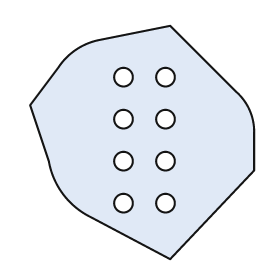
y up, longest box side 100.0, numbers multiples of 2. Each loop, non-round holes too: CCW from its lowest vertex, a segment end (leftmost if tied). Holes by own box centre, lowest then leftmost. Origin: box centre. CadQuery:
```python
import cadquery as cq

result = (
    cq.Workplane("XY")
    .moveTo(12.0, -50.0)
    .lineTo(48.0, -12.0)
    .lineTo(48.0, 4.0)
    .threePointArc((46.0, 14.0), (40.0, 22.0))
    .lineTo(12.0, 50.0)
    .lineTo(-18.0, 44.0)
    .threePointArc((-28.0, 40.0), (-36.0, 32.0))
    .lineTo(-48.0, 16.0)
    .lineTo(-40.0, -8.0)
    .threePointArc((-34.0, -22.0), (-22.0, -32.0))
    .close()
    .moveTo(-8.0, -26.0)
    .circle(4.0)
    .moveTo(10.0, -26.0)
    .circle(4.0)
    .moveTo(-8.0, -8.0)
    .circle(4.0)
    .moveTo(10.0, -8.0)
    .circle(4.0)
    .moveTo(-8.0, 10.0)
    .circle(4.0)
    .moveTo(10.0, 10.0)
    .circle(4.0)
    .moveTo(-8.0, 28.0)
    .circle(4.0)
    .moveTo(10.0, 28.0)
    .circle(4.0)
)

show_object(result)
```